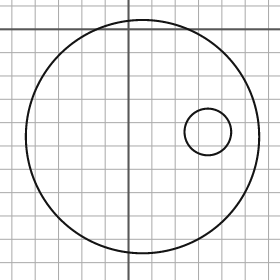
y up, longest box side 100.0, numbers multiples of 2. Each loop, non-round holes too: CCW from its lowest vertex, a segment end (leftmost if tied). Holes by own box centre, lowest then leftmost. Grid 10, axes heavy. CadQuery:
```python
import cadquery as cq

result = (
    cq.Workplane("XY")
    .moveTo(6.0, -46.0)
    .circle(50.0)
    .moveTo(34.0, -44.0)
    .circle(10.0)
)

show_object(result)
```